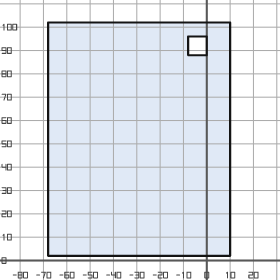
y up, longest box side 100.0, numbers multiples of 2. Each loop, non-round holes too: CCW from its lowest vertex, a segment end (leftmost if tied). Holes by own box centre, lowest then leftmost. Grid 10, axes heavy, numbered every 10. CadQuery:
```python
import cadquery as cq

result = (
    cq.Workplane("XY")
    .moveTo(-68.0, 2.0)
    .lineTo(10.0, 2.0)
    .lineTo(10.0, 102.0)
    .lineTo(-68.0, 102.0)
    .close()
    .moveTo(-8.0, 88.0)
    .lineTo(0.0, 88.0)
    .lineTo(0.0, 96.0)
    .lineTo(-8.0, 96.0)
    .close()
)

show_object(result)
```